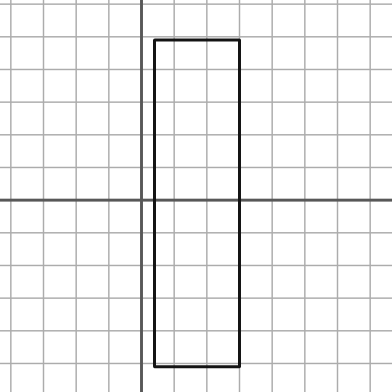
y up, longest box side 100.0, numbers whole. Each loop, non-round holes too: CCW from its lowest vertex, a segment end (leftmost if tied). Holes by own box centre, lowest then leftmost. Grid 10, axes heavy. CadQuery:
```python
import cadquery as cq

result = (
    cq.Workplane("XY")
    .moveTo(4.0, -51.0)
    .lineTo(30.0, -51.0)
    .lineTo(30.0, 49.0)
    .lineTo(4.0, 49.0)
    .close()
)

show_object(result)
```